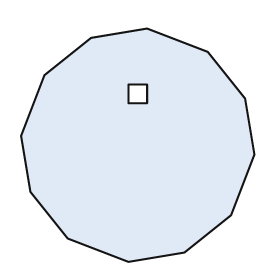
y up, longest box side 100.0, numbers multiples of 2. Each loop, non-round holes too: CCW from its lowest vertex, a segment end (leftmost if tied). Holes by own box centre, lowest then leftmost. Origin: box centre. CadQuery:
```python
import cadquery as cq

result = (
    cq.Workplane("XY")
    .moveTo(-4.0, -50.0)
    .lineTo(20.0, -46.0)
    .lineTo(40.0, -30.0)
    .lineTo(50.0, -4.0)
    .lineTo(46.0, 20.0)
    .lineTo(30.0, 40.0)
    .lineTo(4.0, 50.0)
    .lineTo(-20.0, 46.0)
    .lineTo(-40.0, 30.0)
    .lineTo(-50.0, 4.0)
    .lineTo(-46.0, -20.0)
    .lineTo(-30.0, -40.0)
    .close()
    .moveTo(-4.0, 18.0)
    .lineTo(4.0, 18.0)
    .lineTo(4.0, 26.0)
    .lineTo(-4.0, 26.0)
    .close()
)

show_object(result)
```